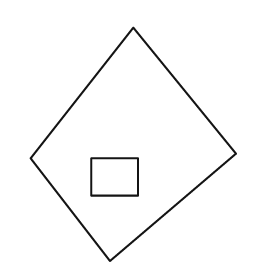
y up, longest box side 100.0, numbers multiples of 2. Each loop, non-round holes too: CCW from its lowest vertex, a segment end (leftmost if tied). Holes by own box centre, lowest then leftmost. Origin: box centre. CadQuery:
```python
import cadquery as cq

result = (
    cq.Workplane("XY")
    .moveTo(-10.0, -50.0)
    .lineTo(44.0, -4.0)
    .lineTo(0.0, 50.0)
    .lineTo(-44.0, -6.0)
    .close()
    .moveTo(-18.0, -22.0)
    .lineTo(2.0, -22.0)
    .lineTo(2.0, -6.0)
    .lineTo(-18.0, -6.0)
    .close()
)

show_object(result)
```